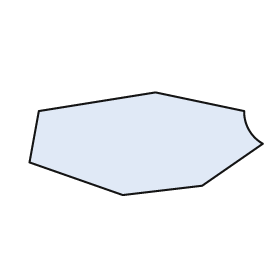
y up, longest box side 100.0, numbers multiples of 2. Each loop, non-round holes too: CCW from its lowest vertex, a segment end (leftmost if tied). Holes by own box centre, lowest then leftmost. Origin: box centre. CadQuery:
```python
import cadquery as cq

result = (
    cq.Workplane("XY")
    .moveTo(-10.0, -22.0)
    .lineTo(24.0, -18.0)
    .lineTo(50.0, 0.0)
    .threePointArc((44.0, 6.0), (42.0, 14.0))
    .lineTo(4.0, 22.0)
    .lineTo(-46.0, 14.0)
    .lineTo(-50.0, -8.0)
    .close()
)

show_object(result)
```